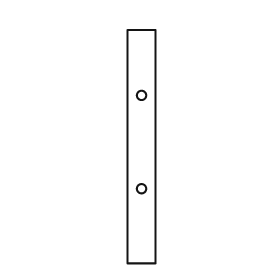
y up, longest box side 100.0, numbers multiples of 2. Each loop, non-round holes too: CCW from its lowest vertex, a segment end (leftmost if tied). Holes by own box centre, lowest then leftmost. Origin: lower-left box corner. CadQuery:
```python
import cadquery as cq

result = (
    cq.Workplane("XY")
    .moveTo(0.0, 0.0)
    .lineTo(12.0, 0.0)
    .lineTo(12.0, 100.0)
    .lineTo(0.0, 100.0)
    .close()
    .moveTo(6.0, 32.0)
    .circle(2.0)
    .moveTo(6.0, 72.0)
    .circle(2.0)
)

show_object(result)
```